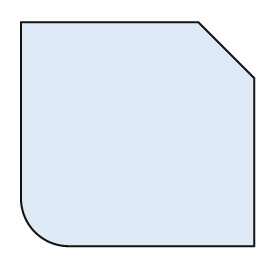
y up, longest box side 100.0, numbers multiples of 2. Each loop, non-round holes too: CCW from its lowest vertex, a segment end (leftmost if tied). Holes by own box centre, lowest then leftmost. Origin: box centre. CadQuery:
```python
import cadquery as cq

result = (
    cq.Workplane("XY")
    .moveTo(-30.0, -48.0)
    .lineTo(50.0, -48.0)
    .lineTo(50.0, 24.0)
    .lineTo(26.0, 48.0)
    .lineTo(-50.0, 48.0)
    .lineTo(-50.0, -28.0)
    .threePointArc((-44.0, -42.0), (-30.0, -48.0))
    .close()
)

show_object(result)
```